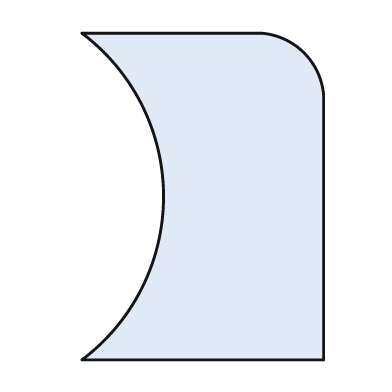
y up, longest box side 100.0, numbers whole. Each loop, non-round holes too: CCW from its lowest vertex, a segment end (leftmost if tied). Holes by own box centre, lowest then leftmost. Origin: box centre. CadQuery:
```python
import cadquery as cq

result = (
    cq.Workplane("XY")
    .moveTo(-37.0, -50.0)
    .lineTo(37.0, -50.0)
    .lineTo(37.0, 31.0)
    .threePointArc((31.0, 44.0), (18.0, 50.0))
    .lineTo(-37.0, 50.0)
    .threePointArc((-12.0, 0.0), (-37.0, -50.0))
    .close()
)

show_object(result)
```